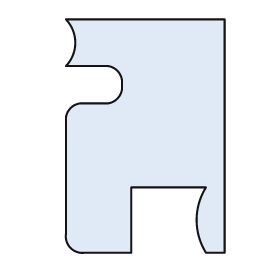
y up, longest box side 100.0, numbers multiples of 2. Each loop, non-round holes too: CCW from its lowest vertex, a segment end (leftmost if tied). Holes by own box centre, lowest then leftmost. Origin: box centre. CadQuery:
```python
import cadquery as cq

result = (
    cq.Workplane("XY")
    .moveTo(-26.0, -50.0)
    .lineTo(-6.0, -50.0)
    .lineTo(-6.0, -22.0)
    .lineTo(26.0, -22.0)
    .threePointArc((22.0, -36.0), (26.0, -50.0))
    .lineTo(34.0, -50.0)
    .lineTo(34.0, 50.0)
    .lineTo(-34.0, 50.0)
    .threePointArc((-30.0, 40.0), (-34.0, 30.0))
    .lineTo(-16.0, 30.0)
    .threePointArc((-12.0, 28.0), (-10.0, 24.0))
    .lineTo(-10.0, 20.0)
    .threePointArc((-12.0, 16.0), (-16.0, 14.0))
    .lineTo(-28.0, 14.0)
    .threePointArc((-32.0, 12.0), (-34.0, 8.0))
    .lineTo(-34.0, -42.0)
    .threePointArc((-32.0, -48.0), (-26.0, -50.0))
    .close()
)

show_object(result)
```